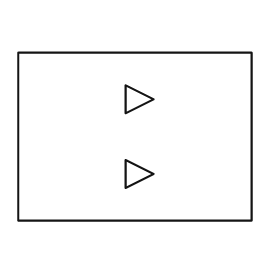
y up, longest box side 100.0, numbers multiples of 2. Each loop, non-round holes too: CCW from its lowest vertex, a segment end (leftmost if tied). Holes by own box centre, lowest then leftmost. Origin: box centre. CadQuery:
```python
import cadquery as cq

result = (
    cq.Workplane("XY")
    .moveTo(-50.0, -36.0)
    .lineTo(50.0, -36.0)
    .lineTo(50.0, 36.0)
    .lineTo(-50.0, 36.0)
    .close()
    .moveTo(-4.0, -22.0)
    .lineTo(8.0, -16.0)
    .lineTo(-4.0, -10.0)
    .close()
    .moveTo(-4.0, 10.0)
    .lineTo(8.0, 16.0)
    .lineTo(-4.0, 22.0)
    .close()
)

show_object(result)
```